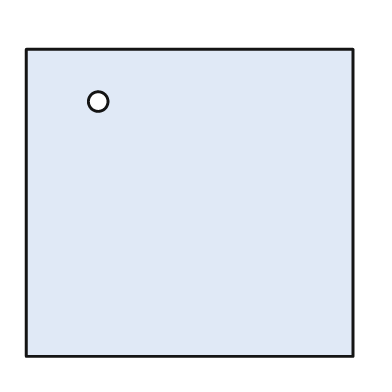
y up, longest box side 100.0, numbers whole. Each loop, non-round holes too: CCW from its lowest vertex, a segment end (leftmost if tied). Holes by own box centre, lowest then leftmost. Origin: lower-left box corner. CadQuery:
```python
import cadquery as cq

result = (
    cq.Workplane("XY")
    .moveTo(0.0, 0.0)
    .lineTo(100.0, 0.0)
    .lineTo(100.0, 94.0)
    .lineTo(0.0, 94.0)
    .close()
    .moveTo(22.0, 78.0)
    .circle(3.0)
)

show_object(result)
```